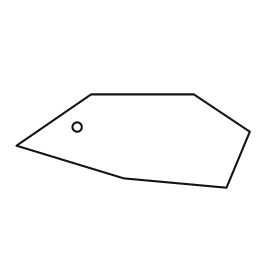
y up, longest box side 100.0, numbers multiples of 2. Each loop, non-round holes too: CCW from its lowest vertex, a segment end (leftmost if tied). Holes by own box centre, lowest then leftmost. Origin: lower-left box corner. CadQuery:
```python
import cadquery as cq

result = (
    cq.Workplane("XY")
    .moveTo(90.0, 0.0)
    .lineTo(100.0, 24.0)
    .lineTo(76.0, 40.0)
    .lineTo(32.0, 40.0)
    .lineTo(0.0, 18.0)
    .lineTo(46.0, 4.0)
    .close()
    .moveTo(26.0, 26.0)
    .circle(2.0)
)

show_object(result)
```